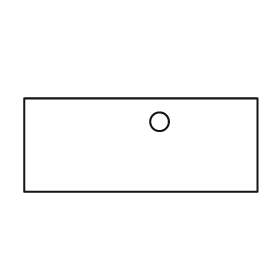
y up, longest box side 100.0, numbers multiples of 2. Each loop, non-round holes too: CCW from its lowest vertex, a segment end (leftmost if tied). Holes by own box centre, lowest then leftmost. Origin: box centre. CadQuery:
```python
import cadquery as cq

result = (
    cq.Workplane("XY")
    .moveTo(-50.0, -20.0)
    .lineTo(50.0, -20.0)
    .lineTo(50.0, 20.0)
    .lineTo(-50.0, 20.0)
    .close()
    .moveTo(8.0, 10.0)
    .circle(4.0)
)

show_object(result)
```